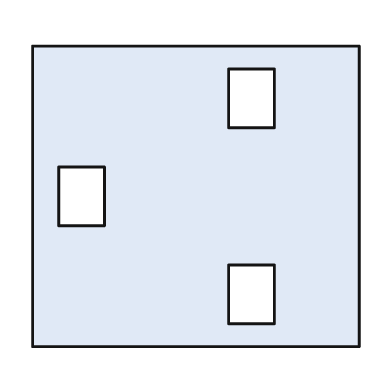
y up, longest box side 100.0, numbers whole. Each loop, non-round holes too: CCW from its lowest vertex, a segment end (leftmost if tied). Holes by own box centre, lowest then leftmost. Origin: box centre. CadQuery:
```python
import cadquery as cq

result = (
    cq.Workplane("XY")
    .moveTo(-50.0, -46.0)
    .lineTo(50.0, -46.0)
    .lineTo(50.0, 46.0)
    .lineTo(-50.0, 46.0)
    .close()
    .moveTo(10.0, -39.0)
    .lineTo(24.0, -39.0)
    .lineTo(24.0, -21.0)
    .lineTo(10.0, -21.0)
    .close()
    .moveTo(-42.0, -9.0)
    .lineTo(-28.0, -9.0)
    .lineTo(-28.0, 9.0)
    .lineTo(-42.0, 9.0)
    .close()
    .moveTo(10.0, 21.0)
    .lineTo(24.0, 21.0)
    .lineTo(24.0, 39.0)
    .lineTo(10.0, 39.0)
    .close()
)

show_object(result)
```